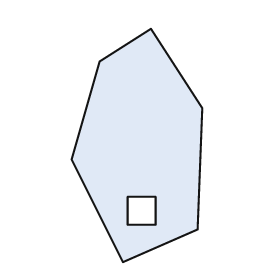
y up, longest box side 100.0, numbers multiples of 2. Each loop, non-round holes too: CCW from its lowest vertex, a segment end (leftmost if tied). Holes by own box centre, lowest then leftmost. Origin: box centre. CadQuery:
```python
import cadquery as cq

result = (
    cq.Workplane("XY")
    .moveTo(-6.0, -50.0)
    .lineTo(26.0, -36.0)
    .lineTo(28.0, 16.0)
    .lineTo(6.0, 50.0)
    .lineTo(-16.0, 36.0)
    .lineTo(-28.0, -6.0)
    .close()
    .moveTo(-4.0, -34.0)
    .lineTo(8.0, -34.0)
    .lineTo(8.0, -22.0)
    .lineTo(-4.0, -22.0)
    .close()
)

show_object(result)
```